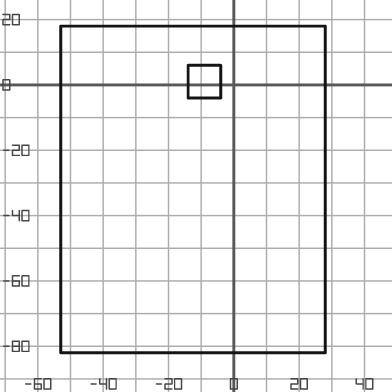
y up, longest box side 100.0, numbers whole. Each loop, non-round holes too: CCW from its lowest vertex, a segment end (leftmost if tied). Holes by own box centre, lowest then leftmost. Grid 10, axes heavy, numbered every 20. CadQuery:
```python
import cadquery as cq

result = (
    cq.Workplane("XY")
    .moveTo(-53.0, -82.0)
    .lineTo(28.0, -82.0)
    .lineTo(28.0, 18.0)
    .lineTo(-53.0, 18.0)
    .close()
    .moveTo(-14.0, -4.0)
    .lineTo(-4.0, -4.0)
    .lineTo(-4.0, 6.0)
    .lineTo(-14.0, 6.0)
    .close()
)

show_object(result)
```